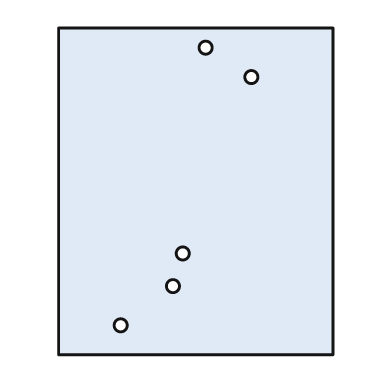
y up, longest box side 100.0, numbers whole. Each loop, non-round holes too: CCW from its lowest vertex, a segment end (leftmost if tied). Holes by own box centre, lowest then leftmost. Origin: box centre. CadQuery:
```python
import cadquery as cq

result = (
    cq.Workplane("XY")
    .moveTo(-42.0, -50.0)
    .lineTo(42.0, -50.0)
    .lineTo(42.0, 50.0)
    .lineTo(-42.0, 50.0)
    .close()
    .moveTo(-23.0, -41.0)
    .circle(2.0)
    .moveTo(-7.0, -29.0)
    .circle(2.0)
    .moveTo(-4.0, -19.0)
    .circle(2.0)
    .moveTo(17.0, 35.0)
    .circle(2.0)
    .moveTo(3.0, 44.0)
    .circle(2.0)
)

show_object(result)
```